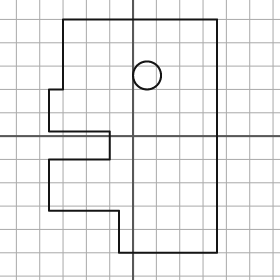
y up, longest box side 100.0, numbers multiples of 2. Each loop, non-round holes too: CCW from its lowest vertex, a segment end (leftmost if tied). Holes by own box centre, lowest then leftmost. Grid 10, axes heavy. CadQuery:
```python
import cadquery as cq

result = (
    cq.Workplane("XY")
    .moveTo(-6.0, -50.0)
    .lineTo(36.0, -50.0)
    .lineTo(36.0, 50.0)
    .lineTo(-30.0, 50.0)
    .lineTo(-30.0, 20.0)
    .lineTo(-36.0, 20.0)
    .lineTo(-36.0, 2.0)
    .lineTo(-10.0, 2.0)
    .lineTo(-10.0, -10.0)
    .lineTo(-36.0, -10.0)
    .lineTo(-36.0, -32.0)
    .lineTo(-6.0, -32.0)
    .close()
    .moveTo(6.0, 26.0)
    .circle(6.0)
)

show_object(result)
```